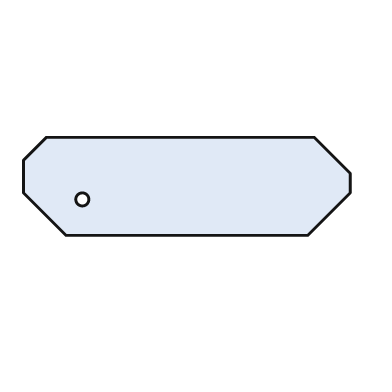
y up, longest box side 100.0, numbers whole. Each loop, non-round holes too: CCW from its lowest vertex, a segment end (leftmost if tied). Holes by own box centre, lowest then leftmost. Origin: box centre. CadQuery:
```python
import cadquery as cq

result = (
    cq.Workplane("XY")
    .moveTo(-37.0, -15.0)
    .lineTo(37.0, -15.0)
    .lineTo(50.0, -2.0)
    .lineTo(50.0, 4.0)
    .lineTo(39.0, 15.0)
    .lineTo(-43.0, 15.0)
    .lineTo(-50.0, 8.0)
    .lineTo(-50.0, -2.0)
    .close()
    .moveTo(-32.0, -4.0)
    .circle(2.0)
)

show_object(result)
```